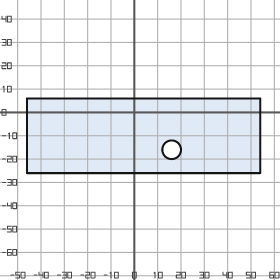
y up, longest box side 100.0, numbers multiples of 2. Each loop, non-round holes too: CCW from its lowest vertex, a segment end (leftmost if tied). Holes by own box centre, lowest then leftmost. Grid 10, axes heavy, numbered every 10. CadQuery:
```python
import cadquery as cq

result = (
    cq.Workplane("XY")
    .moveTo(-46.0, -26.0)
    .lineTo(54.0, -26.0)
    .lineTo(54.0, 6.0)
    .lineTo(-46.0, 6.0)
    .close()
    .moveTo(16.0, -16.0)
    .circle(4.0)
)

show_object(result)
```